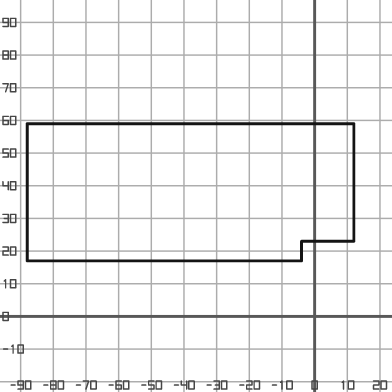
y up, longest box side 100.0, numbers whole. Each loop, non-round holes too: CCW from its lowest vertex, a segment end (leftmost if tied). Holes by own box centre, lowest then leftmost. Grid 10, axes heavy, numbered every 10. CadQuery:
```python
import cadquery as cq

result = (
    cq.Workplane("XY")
    .moveTo(-88.0, 17.0)
    .lineTo(-4.0, 17.0)
    .lineTo(-4.0, 23.0)
    .lineTo(12.0, 23.0)
    .lineTo(12.0, 59.0)
    .lineTo(-88.0, 59.0)
    .close()
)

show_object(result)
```